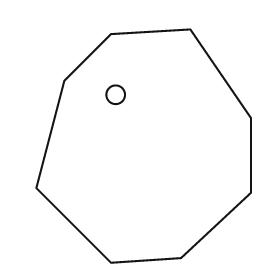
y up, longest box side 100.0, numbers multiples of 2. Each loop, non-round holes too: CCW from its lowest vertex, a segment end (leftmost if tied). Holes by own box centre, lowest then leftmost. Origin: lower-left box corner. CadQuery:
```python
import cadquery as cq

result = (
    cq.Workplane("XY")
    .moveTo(32.0, 0.0)
    .lineTo(62.0, 2.0)
    .lineTo(92.0, 30.0)
    .lineTo(92.0, 62.0)
    .lineTo(66.0, 100.0)
    .lineTo(32.0, 98.0)
    .lineTo(12.0, 78.0)
    .lineTo(0.0, 32.0)
    .close()
    .moveTo(34.0, 72.0)
    .circle(4.0)
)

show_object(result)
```